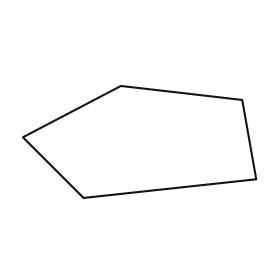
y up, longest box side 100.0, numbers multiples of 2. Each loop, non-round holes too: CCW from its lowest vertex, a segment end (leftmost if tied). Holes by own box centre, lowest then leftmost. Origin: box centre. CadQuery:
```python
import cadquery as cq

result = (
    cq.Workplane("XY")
    .moveTo(-24.0, -24.0)
    .lineTo(50.0, -16.0)
    .lineTo(44.0, 18.0)
    .lineTo(-8.0, 24.0)
    .lineTo(-50.0, 2.0)
    .close()
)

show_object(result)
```